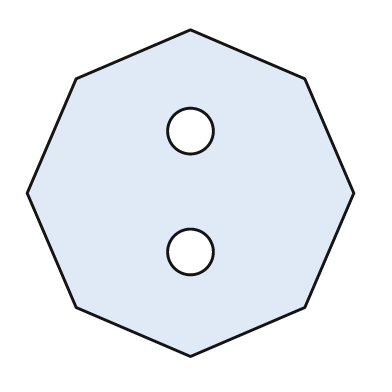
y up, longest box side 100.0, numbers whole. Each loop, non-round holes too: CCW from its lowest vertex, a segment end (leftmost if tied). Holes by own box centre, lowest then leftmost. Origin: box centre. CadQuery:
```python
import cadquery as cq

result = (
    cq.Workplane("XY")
    .moveTo(0.0, -50.0)
    .lineTo(35.0, -35.0)
    .lineTo(50.0, 0.0)
    .lineTo(35.0, 35.0)
    .lineTo(0.0, 50.0)
    .lineTo(-35.0, 35.0)
    .lineTo(-50.0, 0.0)
    .lineTo(-35.0, -35.0)
    .close()
    .moveTo(0.0, -18.0)
    .circle(7.0)
    .moveTo(0.0, 19.0)
    .circle(7.0)
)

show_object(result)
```